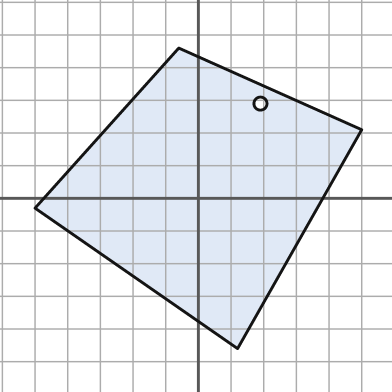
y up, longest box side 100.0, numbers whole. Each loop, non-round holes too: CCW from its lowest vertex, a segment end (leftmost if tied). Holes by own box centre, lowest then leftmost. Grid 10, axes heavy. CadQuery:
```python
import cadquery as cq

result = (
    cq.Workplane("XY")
    .moveTo(12.0, -46.0)
    .lineTo(50.0, 21.0)
    .lineTo(-6.0, 46.0)
    .lineTo(-50.0, -3.0)
    .close()
    .moveTo(19.0, 29.0)
    .circle(2.0)
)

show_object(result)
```